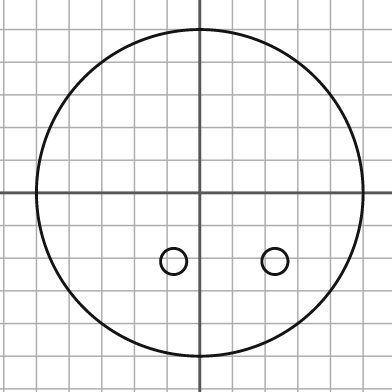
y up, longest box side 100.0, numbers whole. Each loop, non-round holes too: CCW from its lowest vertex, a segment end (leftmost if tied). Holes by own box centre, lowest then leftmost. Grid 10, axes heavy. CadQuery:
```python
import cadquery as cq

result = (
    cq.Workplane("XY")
    .moveTo(0.0, 0.0)
    .circle(50.0)
    .moveTo(-8.0, -21.0)
    .circle(4.0)
    .moveTo(23.0, -21.0)
    .circle(4.0)
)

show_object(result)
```